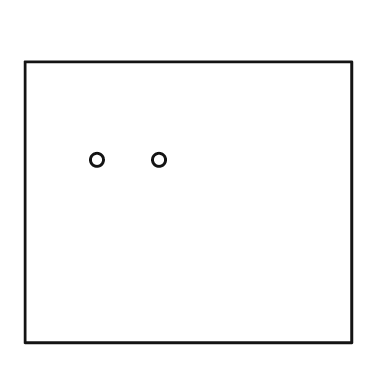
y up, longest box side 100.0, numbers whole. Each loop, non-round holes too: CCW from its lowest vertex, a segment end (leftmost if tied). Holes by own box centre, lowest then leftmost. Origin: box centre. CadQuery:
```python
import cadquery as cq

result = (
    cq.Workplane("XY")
    .moveTo(-50.0, -43.0)
    .lineTo(50.0, -43.0)
    .lineTo(50.0, 43.0)
    .lineTo(-50.0, 43.0)
    .close()
    .moveTo(-28.0, 13.0)
    .circle(2.0)
    .moveTo(-9.0, 13.0)
    .circle(2.0)
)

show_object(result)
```